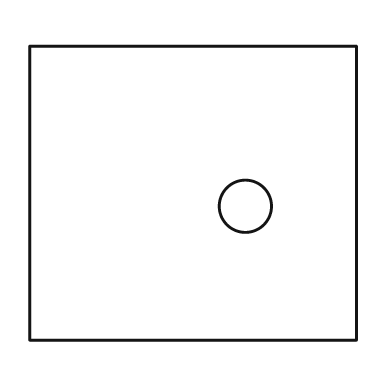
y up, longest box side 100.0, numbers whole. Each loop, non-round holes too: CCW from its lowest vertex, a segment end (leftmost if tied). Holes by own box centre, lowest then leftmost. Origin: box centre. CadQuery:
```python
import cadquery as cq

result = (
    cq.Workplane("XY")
    .moveTo(-50.0, -45.0)
    .lineTo(50.0, -45.0)
    .lineTo(50.0, 45.0)
    .lineTo(-50.0, 45.0)
    .close()
    .moveTo(16.0, -4.0)
    .circle(8.0)
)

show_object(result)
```